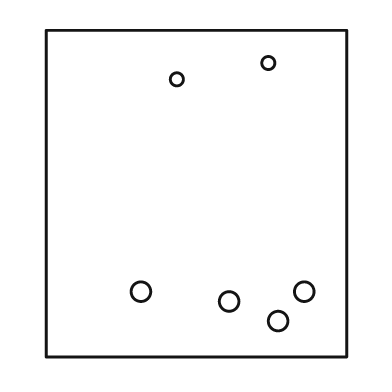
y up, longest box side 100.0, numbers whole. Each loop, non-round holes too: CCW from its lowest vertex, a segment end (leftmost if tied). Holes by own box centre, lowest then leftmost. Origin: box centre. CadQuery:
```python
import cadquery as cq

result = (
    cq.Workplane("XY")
    .moveTo(-46.0, -50.0)
    .lineTo(46.0, -50.0)
    .lineTo(46.0, 50.0)
    .lineTo(-46.0, 50.0)
    .close()
    .moveTo(25.0, -39.0)
    .circle(3.0)
    .moveTo(10.0, -33.0)
    .circle(3.0)
    .moveTo(-17.0, -30.0)
    .circle(3.0)
    .moveTo(33.0, -30.0)
    .circle(3.0)
    .moveTo(-6.0, 35.0)
    .circle(2.0)
    .moveTo(22.0, 40.0)
    .circle(2.0)
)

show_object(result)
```